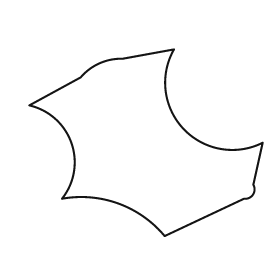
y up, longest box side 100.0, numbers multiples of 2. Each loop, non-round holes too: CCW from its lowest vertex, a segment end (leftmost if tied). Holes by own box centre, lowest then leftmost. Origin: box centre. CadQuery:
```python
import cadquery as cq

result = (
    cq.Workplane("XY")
    .moveTo(8.0, -40.0)
    .lineTo(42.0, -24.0)
    .threePointArc((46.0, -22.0), (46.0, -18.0))
    .lineTo(50.0, 0.0)
    .threePointArc((16.0, 6.0), (12.0, 40.0))
    .lineTo(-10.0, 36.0)
    .threePointArc((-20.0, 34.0), (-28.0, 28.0))
    .lineTo(-50.0, 16.0)
    .threePointArc((-32.0, 0.0), (-36.0, -24.0))
    .threePointArc((-12.0, -26.0), (8.0, -40.0))
    .close()
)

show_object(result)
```